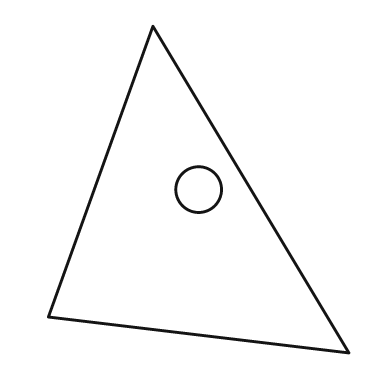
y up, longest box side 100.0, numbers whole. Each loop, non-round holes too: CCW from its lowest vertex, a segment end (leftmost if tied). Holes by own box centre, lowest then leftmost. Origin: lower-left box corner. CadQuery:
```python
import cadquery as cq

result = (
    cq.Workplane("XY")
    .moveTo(92.0, 0.0)
    .lineTo(32.0, 100.0)
    .lineTo(0.0, 11.0)
    .close()
    .moveTo(46.0, 50.0)
    .circle(7.0)
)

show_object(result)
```